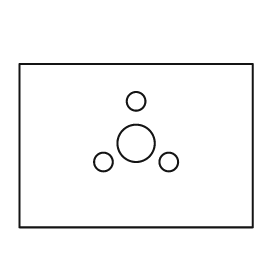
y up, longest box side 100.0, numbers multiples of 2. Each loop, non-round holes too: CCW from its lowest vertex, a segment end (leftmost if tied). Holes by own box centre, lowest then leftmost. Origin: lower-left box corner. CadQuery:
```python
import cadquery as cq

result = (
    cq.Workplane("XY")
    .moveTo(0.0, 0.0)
    .lineTo(100.0, 0.0)
    .lineTo(100.0, 70.0)
    .lineTo(0.0, 70.0)
    .close()
    .moveTo(36.0, 28.0)
    .circle(4.0)
    .moveTo(64.0, 28.0)
    .circle(4.0)
    .moveTo(50.0, 36.0)
    .circle(8.0)
    .moveTo(50.0, 54.0)
    .circle(4.0)
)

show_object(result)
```